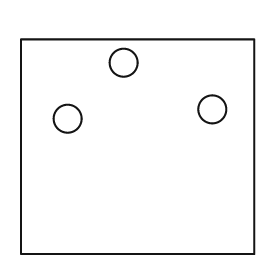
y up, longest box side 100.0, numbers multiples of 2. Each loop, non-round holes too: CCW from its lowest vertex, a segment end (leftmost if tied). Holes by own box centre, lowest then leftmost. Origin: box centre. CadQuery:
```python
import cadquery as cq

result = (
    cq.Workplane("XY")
    .moveTo(-50.0, -46.0)
    .lineTo(50.0, -46.0)
    .lineTo(50.0, 46.0)
    .lineTo(-50.0, 46.0)
    .close()
    .moveTo(-30.0, 12.0)
    .circle(6.0)
    .moveTo(32.0, 16.0)
    .circle(6.0)
    .moveTo(-6.0, 36.0)
    .circle(6.0)
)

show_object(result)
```